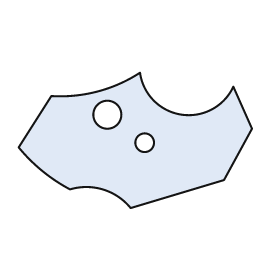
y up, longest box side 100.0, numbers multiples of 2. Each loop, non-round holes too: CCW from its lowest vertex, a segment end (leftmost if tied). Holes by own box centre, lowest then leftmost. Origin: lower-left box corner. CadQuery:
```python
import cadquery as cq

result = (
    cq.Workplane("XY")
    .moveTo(48.0, 0.0)
    .lineTo(88.0, 12.0)
    .lineTo(100.0, 34.0)
    .lineTo(92.0, 52.0)
    .threePointArc((70.0, 40.0), (52.0, 58.0))
    .threePointArc((34.0, 50.0), (14.0, 48.0))
    .lineTo(0.0, 26.0)
    .threePointArc((10.0, 16.0), (22.0, 8.0))
    .threePointArc((36.0, 8.0), (48.0, 0.0))
    .close()
    .moveTo(54.0, 28.0)
    .circle(4.0)
    .moveTo(38.0, 40.0)
    .circle(6.0)
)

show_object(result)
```